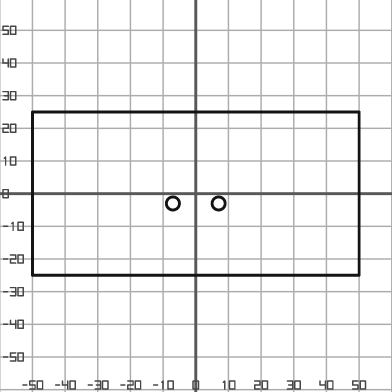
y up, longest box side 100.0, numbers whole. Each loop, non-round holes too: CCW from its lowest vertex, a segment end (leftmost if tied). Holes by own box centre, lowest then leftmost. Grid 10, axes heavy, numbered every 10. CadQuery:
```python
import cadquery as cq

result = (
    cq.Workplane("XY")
    .moveTo(-50.0, -25.0)
    .lineTo(50.0, -25.0)
    .lineTo(50.0, 25.0)
    .lineTo(-50.0, 25.0)
    .close()
    .moveTo(-7.0, -3.0)
    .circle(2.0)
    .moveTo(7.0, -3.0)
    .circle(2.0)
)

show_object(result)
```